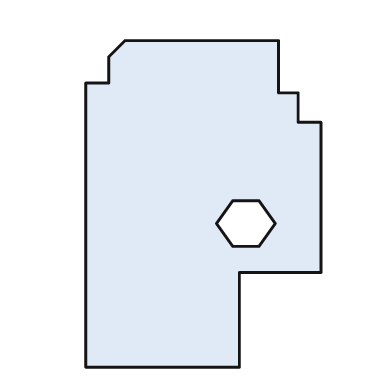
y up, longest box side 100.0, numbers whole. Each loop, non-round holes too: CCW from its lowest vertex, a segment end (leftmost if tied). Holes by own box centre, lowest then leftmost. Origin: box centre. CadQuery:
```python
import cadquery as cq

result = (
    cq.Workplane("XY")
    .moveTo(-36.0, -50.0)
    .lineTo(11.0, -50.0)
    .lineTo(11.0, -21.0)
    .lineTo(36.0, -21.0)
    .lineTo(36.0, 25.0)
    .lineTo(29.0, 25.0)
    .lineTo(29.0, 34.0)
    .lineTo(23.0, 34.0)
    .lineTo(23.0, 50.0)
    .lineTo(-24.0, 50.0)
    .lineTo(-29.0, 45.0)
    .lineTo(-29.0, 37.0)
    .lineTo(-36.0, 37.0)
    .close()
    .moveTo(9.0, -13.0)
    .lineTo(17.0, -13.0)
    .lineTo(22.0, -6.0)
    .lineTo(17.0, 1.0)
    .lineTo(9.0, 1.0)
    .lineTo(4.0, -6.0)
    .close()
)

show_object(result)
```